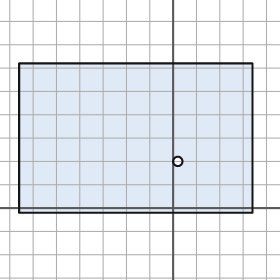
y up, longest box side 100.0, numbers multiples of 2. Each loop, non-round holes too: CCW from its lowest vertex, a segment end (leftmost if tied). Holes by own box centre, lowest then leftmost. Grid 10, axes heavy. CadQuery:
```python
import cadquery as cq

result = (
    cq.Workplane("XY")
    .moveTo(-66.0, -2.0)
    .lineTo(34.0, -2.0)
    .lineTo(34.0, 62.0)
    .lineTo(-66.0, 62.0)
    .close()
    .moveTo(2.0, 20.0)
    .circle(2.0)
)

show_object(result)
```